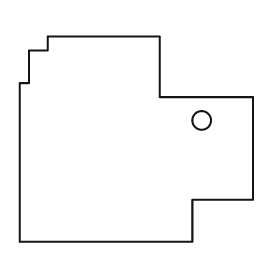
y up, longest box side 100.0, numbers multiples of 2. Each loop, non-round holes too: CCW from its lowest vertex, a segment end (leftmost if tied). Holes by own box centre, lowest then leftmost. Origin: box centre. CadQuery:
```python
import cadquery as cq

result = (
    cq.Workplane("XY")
    .moveTo(-50.0, -44.0)
    .lineTo(24.0, -44.0)
    .lineTo(24.0, -26.0)
    .lineTo(50.0, -26.0)
    .lineTo(50.0, 18.0)
    .lineTo(10.0, 18.0)
    .lineTo(10.0, 44.0)
    .lineTo(-38.0, 44.0)
    .lineTo(-38.0, 38.0)
    .lineTo(-46.0, 38.0)
    .lineTo(-46.0, 24.0)
    .lineTo(-50.0, 24.0)
    .close()
    .moveTo(28.0, 8.0)
    .circle(4.0)
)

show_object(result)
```